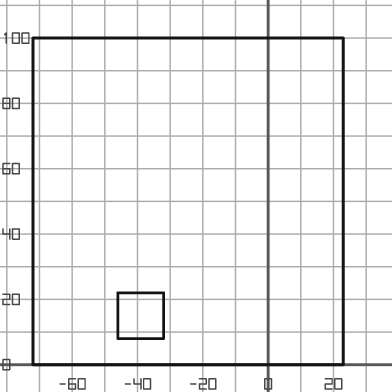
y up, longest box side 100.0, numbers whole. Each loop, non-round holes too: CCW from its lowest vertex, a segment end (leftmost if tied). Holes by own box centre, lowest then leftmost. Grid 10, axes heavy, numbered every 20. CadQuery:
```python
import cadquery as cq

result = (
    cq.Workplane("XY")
    .moveTo(-72.0, 0.0)
    .lineTo(23.0, 0.0)
    .lineTo(23.0, 100.0)
    .lineTo(-72.0, 100.0)
    .close()
    .moveTo(-46.0, 8.0)
    .lineTo(-32.0, 8.0)
    .lineTo(-32.0, 22.0)
    .lineTo(-46.0, 22.0)
    .close()
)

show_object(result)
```